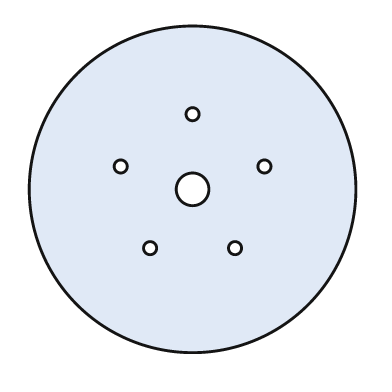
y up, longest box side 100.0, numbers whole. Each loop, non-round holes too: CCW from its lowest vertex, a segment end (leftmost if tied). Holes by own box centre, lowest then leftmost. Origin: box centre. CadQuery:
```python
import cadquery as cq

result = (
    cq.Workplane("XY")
    .moveTo(0.0, 0.0)
    .circle(50.0)
    .moveTo(-13.0, -18.0)
    .circle(2.0)
    .moveTo(13.0, -18.0)
    .circle(2.0)
    .moveTo(0.0, 0.0)
    .circle(5.0)
    .moveTo(-22.0, 7.0)
    .circle(2.0)
    .moveTo(22.0, 7.0)
    .circle(2.0)
    .moveTo(0.0, 23.0)
    .circle(2.0)
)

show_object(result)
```